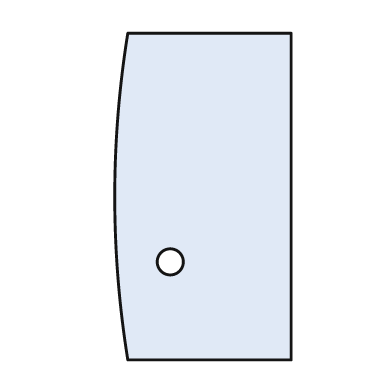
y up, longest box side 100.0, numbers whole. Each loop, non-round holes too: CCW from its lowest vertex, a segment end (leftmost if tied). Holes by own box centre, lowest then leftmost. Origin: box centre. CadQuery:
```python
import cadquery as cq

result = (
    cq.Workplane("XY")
    .moveTo(-23.0, -50.0)
    .lineTo(27.0, -50.0)
    .lineTo(27.0, 50.0)
    .lineTo(-23.0, 50.0)
    .threePointArc((-27.0, 0.0), (-23.0, -50.0))
    .close()
    .moveTo(-10.0, -20.0)
    .circle(4.0)
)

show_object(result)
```